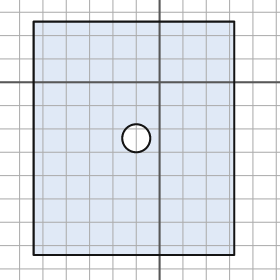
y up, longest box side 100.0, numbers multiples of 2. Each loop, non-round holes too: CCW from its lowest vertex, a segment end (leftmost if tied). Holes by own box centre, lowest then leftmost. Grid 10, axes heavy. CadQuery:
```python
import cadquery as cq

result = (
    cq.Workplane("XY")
    .moveTo(-54.0, -74.0)
    .lineTo(32.0, -74.0)
    .lineTo(32.0, 26.0)
    .lineTo(-54.0, 26.0)
    .close()
    .moveTo(-10.0, -24.0)
    .circle(6.0)
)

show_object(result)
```